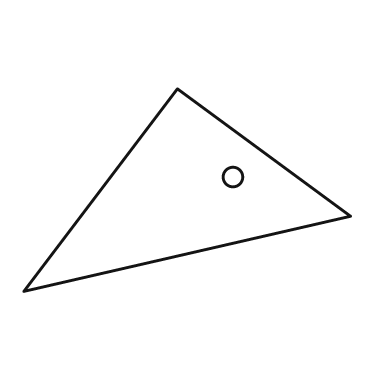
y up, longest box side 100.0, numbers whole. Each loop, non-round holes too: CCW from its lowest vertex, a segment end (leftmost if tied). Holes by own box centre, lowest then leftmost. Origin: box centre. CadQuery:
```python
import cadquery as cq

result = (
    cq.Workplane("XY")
    .moveTo(-50.0, -31.0)
    .lineTo(50.0, -8.0)
    .lineTo(-3.0, 31.0)
    .close()
    .moveTo(14.0, 4.0)
    .circle(3.0)
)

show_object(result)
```